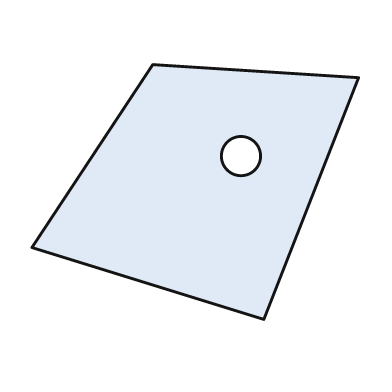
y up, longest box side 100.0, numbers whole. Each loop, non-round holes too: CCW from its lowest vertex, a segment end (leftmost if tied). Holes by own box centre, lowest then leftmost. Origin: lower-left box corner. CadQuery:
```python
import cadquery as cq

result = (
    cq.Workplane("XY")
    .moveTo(71.0, 0.0)
    .lineTo(100.0, 74.0)
    .lineTo(37.0, 78.0)
    .lineTo(0.0, 22.0)
    .close()
    .moveTo(64.0, 50.0)
    .circle(6.0)
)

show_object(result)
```